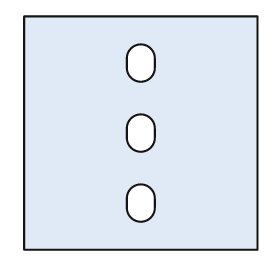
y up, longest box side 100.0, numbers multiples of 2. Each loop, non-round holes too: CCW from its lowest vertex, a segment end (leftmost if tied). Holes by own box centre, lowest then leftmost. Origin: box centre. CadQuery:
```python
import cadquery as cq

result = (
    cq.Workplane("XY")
    .moveTo(-50.0, -50.0)
    .lineTo(50.0, -50.0)
    .lineTo(50.0, 50.0)
    .lineTo(-50.0, 50.0)
    .close()
    .moveTo(-6.0, -32.0)
    .threePointArc((0.0, -38.0), (6.0, -32.0))
    .lineTo(6.0, -28.0)
    .threePointArc((0.0, -22.0), (-6.0, -28.0))
    .close()
    .moveTo(-6.0, -2.0)
    .threePointArc((0.0, -8.0), (6.0, -2.0))
    .lineTo(6.0, 2.0)
    .threePointArc((0.0, 8.0), (-6.0, 2.0))
    .close()
    .moveTo(-6.0, 28.0)
    .threePointArc((0.0, 22.0), (6.0, 28.0))
    .lineTo(6.0, 32.0)
    .threePointArc((0.0, 38.0), (-6.0, 32.0))
    .close()
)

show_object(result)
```